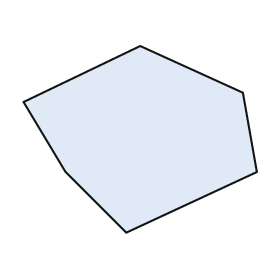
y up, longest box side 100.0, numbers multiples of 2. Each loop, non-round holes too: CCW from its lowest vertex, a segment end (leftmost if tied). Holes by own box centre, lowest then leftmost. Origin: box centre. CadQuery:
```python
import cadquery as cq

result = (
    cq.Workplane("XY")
    .moveTo(-6.0, -40.0)
    .lineTo(50.0, -14.0)
    .lineTo(44.0, 20.0)
    .lineTo(0.0, 40.0)
    .lineTo(-50.0, 16.0)
    .lineTo(-32.0, -14.0)
    .close()
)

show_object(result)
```